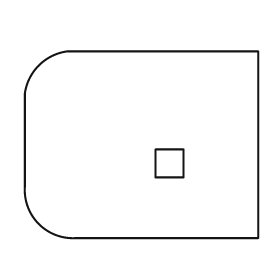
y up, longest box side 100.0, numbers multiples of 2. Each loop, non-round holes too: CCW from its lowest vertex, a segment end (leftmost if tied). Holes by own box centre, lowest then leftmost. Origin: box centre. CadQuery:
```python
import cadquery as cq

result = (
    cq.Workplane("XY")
    .moveTo(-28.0, -40.0)
    .lineTo(50.0, -40.0)
    .lineTo(50.0, 40.0)
    .lineTo(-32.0, 40.0)
    .threePointArc((-44.0, 34.0), (-50.0, 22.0))
    .lineTo(-50.0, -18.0)
    .threePointArc((-44.0, -34.0), (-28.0, -40.0))
    .close()
    .moveTo(6.0, -14.0)
    .lineTo(18.0, -14.0)
    .lineTo(18.0, -2.0)
    .lineTo(6.0, -2.0)
    .close()
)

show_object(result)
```